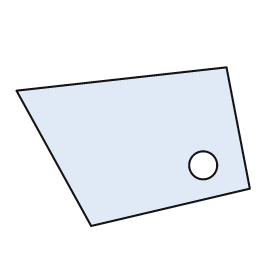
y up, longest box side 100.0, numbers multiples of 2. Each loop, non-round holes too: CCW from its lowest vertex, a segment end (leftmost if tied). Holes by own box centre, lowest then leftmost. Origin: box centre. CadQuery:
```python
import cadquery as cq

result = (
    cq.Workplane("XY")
    .moveTo(-18.0, -34.0)
    .lineTo(50.0, -18.0)
    .lineTo(40.0, 34.0)
    .lineTo(-50.0, 24.0)
    .close()
    .moveTo(30.0, -8.0)
    .circle(6.0)
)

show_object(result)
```